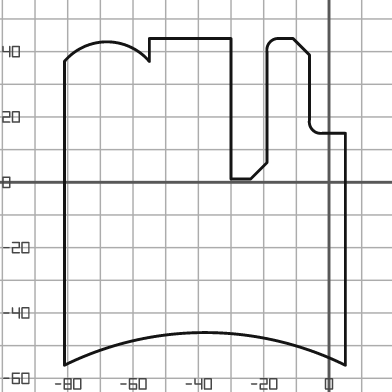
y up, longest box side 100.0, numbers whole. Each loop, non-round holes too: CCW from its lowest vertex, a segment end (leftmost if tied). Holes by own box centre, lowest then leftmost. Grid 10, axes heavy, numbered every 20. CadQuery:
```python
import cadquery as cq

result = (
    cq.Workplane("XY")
    .moveTo(-81.0, -56.0)
    .threePointArc((-38.0, -46.0), (5.0, -56.0))
    .lineTo(5.0, 15.0)
    .lineTo(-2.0, 15.0)
    .threePointArc((-5.0, 16.0), (-6.0, 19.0))
    .lineTo(-6.0, 39.0)
    .lineTo(-11.0, 44.0)
    .lineTo(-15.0, 44.0)
    .threePointArc((-18.0, 43.0), (-19.0, 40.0))
    .lineTo(-19.0, 6.0)
    .lineTo(-24.0, 1.0)
    .lineTo(-30.0, 1.0)
    .lineTo(-30.0, 44.0)
    .lineTo(-55.0, 44.0)
    .lineTo(-55.0, 37.0)
    .threePointArc((-68.0, 43.0), (-81.0, 37.0))
    .close()
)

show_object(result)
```